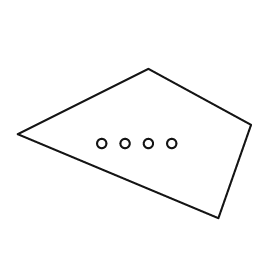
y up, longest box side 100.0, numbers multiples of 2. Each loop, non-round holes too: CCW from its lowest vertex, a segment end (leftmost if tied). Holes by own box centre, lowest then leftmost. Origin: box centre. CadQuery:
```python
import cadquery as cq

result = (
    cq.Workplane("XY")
    .moveTo(36.0, -32.0)
    .lineTo(50.0, 8.0)
    .lineTo(6.0, 32.0)
    .lineTo(-50.0, 4.0)
    .close()
    .moveTo(-14.0, 0.0)
    .circle(2.0)
    .moveTo(-4.0, 0.0)
    .circle(2.0)
    .moveTo(6.0, 0.0)
    .circle(2.0)
    .moveTo(16.0, 0.0)
    .circle(2.0)
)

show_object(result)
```